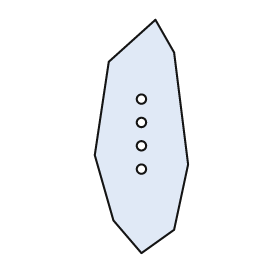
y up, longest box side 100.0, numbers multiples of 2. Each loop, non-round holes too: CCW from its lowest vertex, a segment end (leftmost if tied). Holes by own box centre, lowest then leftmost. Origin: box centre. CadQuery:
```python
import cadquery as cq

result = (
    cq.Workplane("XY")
    .moveTo(0.0, -50.0)
    .lineTo(14.0, -40.0)
    .lineTo(20.0, -12.0)
    .lineTo(14.0, 36.0)
    .lineTo(6.0, 50.0)
    .lineTo(-14.0, 32.0)
    .lineTo(-20.0, -8.0)
    .lineTo(-12.0, -36.0)
    .close()
    .moveTo(0.0, -14.0)
    .circle(2.0)
    .moveTo(0.0, -4.0)
    .circle(2.0)
    .moveTo(0.0, 6.0)
    .circle(2.0)
    .moveTo(0.0, 16.0)
    .circle(2.0)
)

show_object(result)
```